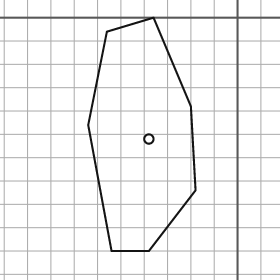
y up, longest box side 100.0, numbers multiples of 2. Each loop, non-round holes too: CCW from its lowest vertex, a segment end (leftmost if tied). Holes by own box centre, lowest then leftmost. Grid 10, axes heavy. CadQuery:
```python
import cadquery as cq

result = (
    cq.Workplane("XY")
    .moveTo(-54.0, -100.0)
    .lineTo(-38.0, -100.0)
    .lineTo(-18.0, -74.0)
    .lineTo(-20.0, -38.0)
    .lineTo(-36.0, 0.0)
    .lineTo(-56.0, -6.0)
    .lineTo(-64.0, -46.0)
    .close()
    .moveTo(-38.0, -52.0)
    .circle(2.0)
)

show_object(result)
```